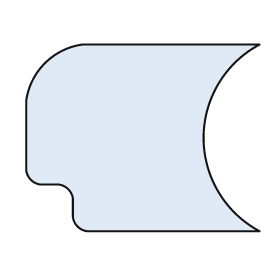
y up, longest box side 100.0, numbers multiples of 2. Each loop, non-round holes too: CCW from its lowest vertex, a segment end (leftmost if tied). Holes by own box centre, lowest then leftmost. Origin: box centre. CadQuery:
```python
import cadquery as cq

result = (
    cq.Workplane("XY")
    .moveTo(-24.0, -40.0)
    .lineTo(50.0, -40.0)
    .threePointArc((26.0, 0.0), (50.0, 40.0))
    .lineTo(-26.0, 40.0)
    .threePointArc((-42.0, 32.0), (-50.0, 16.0))
    .lineTo(-50.0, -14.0)
    .threePointArc((-48.0, -18.0), (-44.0, -20.0))
    .lineTo(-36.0, -20.0)
    .threePointArc((-32.0, -22.0), (-30.0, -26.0))
    .lineTo(-30.0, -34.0)
    .threePointArc((-28.0, -38.0), (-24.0, -40.0))
    .close()
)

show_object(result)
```